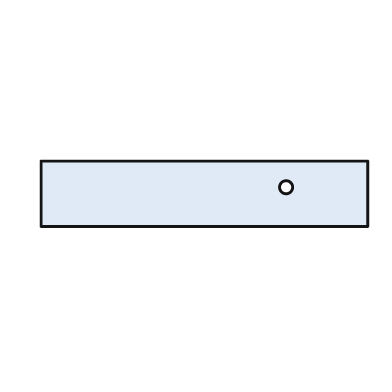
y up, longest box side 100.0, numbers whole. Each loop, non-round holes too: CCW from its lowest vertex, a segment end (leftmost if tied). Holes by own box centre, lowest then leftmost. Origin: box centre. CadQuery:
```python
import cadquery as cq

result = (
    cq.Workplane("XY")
    .moveTo(-50.0, -10.0)
    .lineTo(50.0, -10.0)
    .lineTo(50.0, 10.0)
    .lineTo(-50.0, 10.0)
    .close()
    .moveTo(25.0, 2.0)
    .circle(2.0)
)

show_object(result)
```